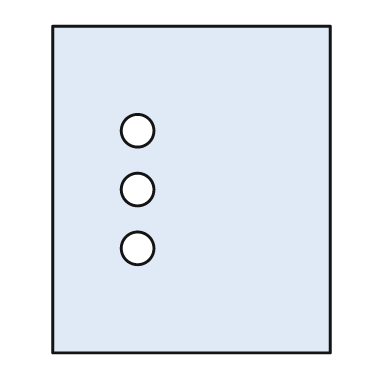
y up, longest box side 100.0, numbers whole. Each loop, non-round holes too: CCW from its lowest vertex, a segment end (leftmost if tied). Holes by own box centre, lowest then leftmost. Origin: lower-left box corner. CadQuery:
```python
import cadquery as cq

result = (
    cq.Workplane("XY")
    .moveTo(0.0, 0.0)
    .lineTo(85.0, 0.0)
    .lineTo(85.0, 100.0)
    .lineTo(0.0, 100.0)
    .close()
    .moveTo(26.0, 32.0)
    .circle(5.0)
    .moveTo(26.0, 50.0)
    .circle(5.0)
    .moveTo(26.0, 68.0)
    .circle(5.0)
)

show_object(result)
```